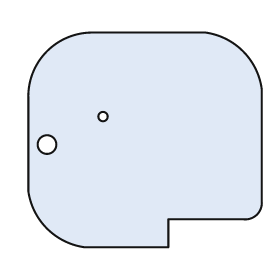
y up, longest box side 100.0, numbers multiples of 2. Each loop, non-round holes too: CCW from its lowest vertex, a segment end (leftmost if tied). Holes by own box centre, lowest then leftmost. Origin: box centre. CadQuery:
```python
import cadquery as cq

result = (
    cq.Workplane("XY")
    .moveTo(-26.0, -46.0)
    .lineTo(10.0, -46.0)
    .lineTo(10.0, -34.0)
    .lineTo(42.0, -34.0)
    .threePointArc((48.0, -32.0), (50.0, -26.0))
    .lineTo(50.0, 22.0)
    .threePointArc((42.0, 38.0), (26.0, 46.0))
    .lineTo(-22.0, 46.0)
    .threePointArc((-42.0, 38.0), (-50.0, 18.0))
    .lineTo(-50.0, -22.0)
    .threePointArc((-42.0, -38.0), (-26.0, -46.0))
    .close()
    .moveTo(-42.0, -2.0)
    .circle(4.0)
    .moveTo(-18.0, 10.0)
    .circle(2.0)
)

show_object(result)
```